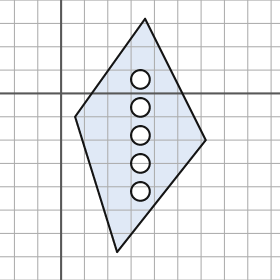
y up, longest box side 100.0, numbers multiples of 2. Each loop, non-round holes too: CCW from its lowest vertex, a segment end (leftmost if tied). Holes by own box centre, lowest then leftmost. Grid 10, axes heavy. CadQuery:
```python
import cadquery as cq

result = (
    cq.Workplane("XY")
    .moveTo(24.0, -68.0)
    .lineTo(62.0, -20.0)
    .lineTo(36.0, 32.0)
    .lineTo(6.0, -10.0)
    .close()
    .moveTo(34.0, -42.0)
    .circle(4.0)
    .moveTo(34.0, -30.0)
    .circle(4.0)
    .moveTo(34.0, -18.0)
    .circle(4.0)
    .moveTo(34.0, -6.0)
    .circle(4.0)
    .moveTo(34.0, 6.0)
    .circle(4.0)
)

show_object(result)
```